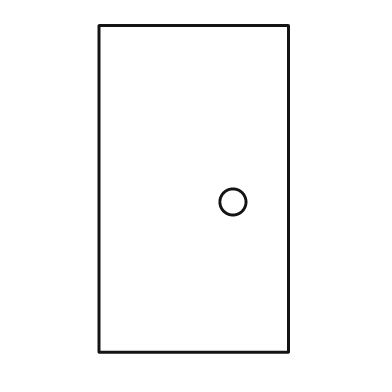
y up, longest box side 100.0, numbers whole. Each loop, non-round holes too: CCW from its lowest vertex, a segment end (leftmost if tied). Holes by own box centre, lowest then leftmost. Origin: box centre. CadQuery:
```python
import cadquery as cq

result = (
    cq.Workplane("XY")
    .moveTo(-29.0, -50.0)
    .lineTo(29.0, -50.0)
    .lineTo(29.0, 50.0)
    .lineTo(-29.0, 50.0)
    .close()
    .moveTo(12.0, -4.0)
    .circle(4.0)
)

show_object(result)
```